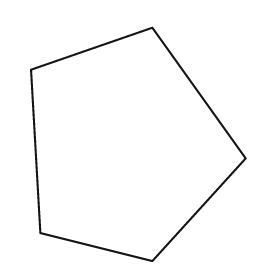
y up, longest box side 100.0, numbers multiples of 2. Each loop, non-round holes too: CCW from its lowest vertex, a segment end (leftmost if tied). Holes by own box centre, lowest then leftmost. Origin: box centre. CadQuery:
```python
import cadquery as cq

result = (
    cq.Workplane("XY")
    .moveTo(6.0, -50.0)
    .lineTo(46.0, -6.0)
    .lineTo(6.0, 50.0)
    .lineTo(-46.0, 32.0)
    .lineTo(-42.0, -38.0)
    .close()
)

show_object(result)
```